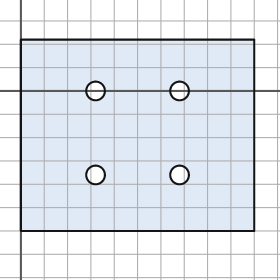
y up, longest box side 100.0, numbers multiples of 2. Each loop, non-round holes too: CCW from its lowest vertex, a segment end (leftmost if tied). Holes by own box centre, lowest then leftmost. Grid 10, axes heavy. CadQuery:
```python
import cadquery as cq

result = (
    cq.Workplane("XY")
    .moveTo(0.0, -60.0)
    .lineTo(100.0, -60.0)
    .lineTo(100.0, 22.0)
    .lineTo(0.0, 22.0)
    .close()
    .moveTo(32.0, -36.0)
    .circle(4.0)
    .moveTo(68.0, -36.0)
    .circle(4.0)
    .moveTo(32.0, 0.0)
    .circle(4.0)
    .moveTo(68.0, 0.0)
    .circle(4.0)
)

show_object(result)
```